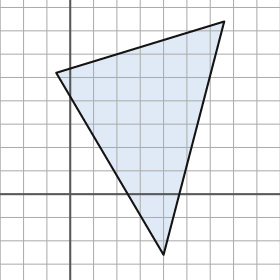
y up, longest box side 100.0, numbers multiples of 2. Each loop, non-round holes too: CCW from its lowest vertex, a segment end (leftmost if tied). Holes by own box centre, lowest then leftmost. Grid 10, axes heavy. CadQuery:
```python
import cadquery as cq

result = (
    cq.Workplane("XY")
    .moveTo(40.0, -26.0)
    .lineTo(66.0, 74.0)
    .lineTo(-6.0, 52.0)
    .close()
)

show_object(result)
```